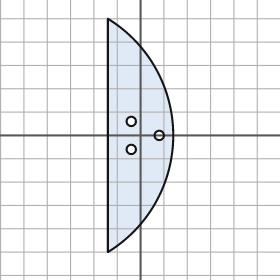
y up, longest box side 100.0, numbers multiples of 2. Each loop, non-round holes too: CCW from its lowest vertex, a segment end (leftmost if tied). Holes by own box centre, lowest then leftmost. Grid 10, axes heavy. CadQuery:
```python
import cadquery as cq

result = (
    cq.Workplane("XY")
    .moveTo(-14.0, -50.0)
    .threePointArc((14.0, 0.0), (-14.0, 50.0))
    .close()
    .moveTo(-4.0, -6.0)
    .circle(2.0)
    .moveTo(8.0, 0.0)
    .circle(2.0)
    .moveTo(-4.0, 6.0)
    .circle(2.0)
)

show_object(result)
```